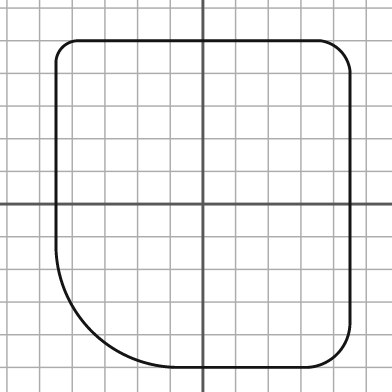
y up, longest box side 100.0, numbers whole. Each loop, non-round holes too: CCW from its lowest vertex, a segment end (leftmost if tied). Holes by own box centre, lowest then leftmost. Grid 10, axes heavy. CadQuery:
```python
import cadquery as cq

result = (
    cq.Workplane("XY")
    .moveTo(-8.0, -50.0)
    .lineTo(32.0, -50.0)
    .threePointArc((41.0, -46.0), (45.0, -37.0))
    .lineTo(45.0, 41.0)
    .threePointArc((42.0, 47.0), (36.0, 50.0))
    .lineTo(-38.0, 50.0)
    .threePointArc((-43.0, 48.0), (-45.0, 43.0))
    .lineTo(-45.0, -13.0)
    .threePointArc((-34.0, -39.0), (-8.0, -50.0))
    .close()
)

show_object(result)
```